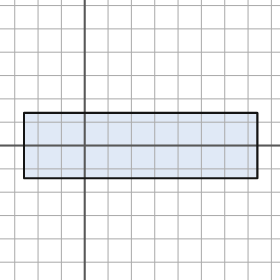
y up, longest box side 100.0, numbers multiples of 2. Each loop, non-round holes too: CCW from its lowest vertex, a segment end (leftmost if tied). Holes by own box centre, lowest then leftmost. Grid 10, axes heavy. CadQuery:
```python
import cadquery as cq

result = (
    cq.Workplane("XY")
    .moveTo(-26.0, -14.0)
    .lineTo(74.0, -14.0)
    .lineTo(74.0, 14.0)
    .lineTo(-26.0, 14.0)
    .close()
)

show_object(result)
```